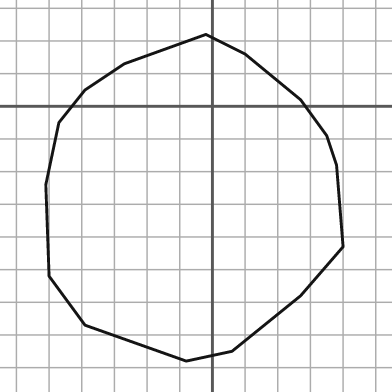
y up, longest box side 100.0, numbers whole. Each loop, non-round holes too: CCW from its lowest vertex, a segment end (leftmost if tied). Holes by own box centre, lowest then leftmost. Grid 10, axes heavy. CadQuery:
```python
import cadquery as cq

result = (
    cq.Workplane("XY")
    .moveTo(-8.0, -78.0)
    .lineTo(6.0, -75.0)
    .lineTo(27.0, -58.0)
    .lineTo(40.0, -43.0)
    .lineTo(38.0, -18.0)
    .lineTo(35.0, -9.0)
    .lineTo(27.0, 2.0)
    .lineTo(10.0, 16.0)
    .lineTo(-2.0, 22.0)
    .lineTo(-27.0, 13.0)
    .lineTo(-39.0, 5.0)
    .lineTo(-47.0, -5.0)
    .lineTo(-51.0, -24.0)
    .lineTo(-50.0, -52.0)
    .lineTo(-39.0, -67.0)
    .close()
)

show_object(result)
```